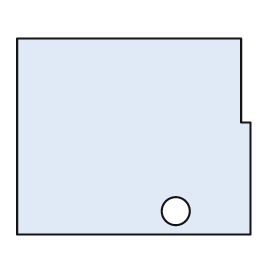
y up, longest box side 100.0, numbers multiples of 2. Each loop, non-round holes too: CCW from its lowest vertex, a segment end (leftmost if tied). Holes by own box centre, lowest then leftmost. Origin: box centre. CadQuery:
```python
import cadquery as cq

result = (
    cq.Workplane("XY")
    .moveTo(-50.0, -42.0)
    .lineTo(50.0, -42.0)
    .lineTo(50.0, 6.0)
    .lineTo(46.0, 6.0)
    .lineTo(46.0, 42.0)
    .lineTo(-50.0, 42.0)
    .close()
    .moveTo(18.0, -32.0)
    .circle(6.0)
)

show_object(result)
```